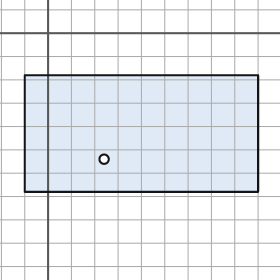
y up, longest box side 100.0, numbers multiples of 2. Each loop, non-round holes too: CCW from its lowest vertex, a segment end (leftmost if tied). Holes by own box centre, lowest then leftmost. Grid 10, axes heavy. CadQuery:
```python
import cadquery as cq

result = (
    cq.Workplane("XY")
    .moveTo(-10.0, -68.0)
    .lineTo(90.0, -68.0)
    .lineTo(90.0, -18.0)
    .lineTo(-10.0, -18.0)
    .close()
    .moveTo(24.0, -54.0)
    .circle(2.0)
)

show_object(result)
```